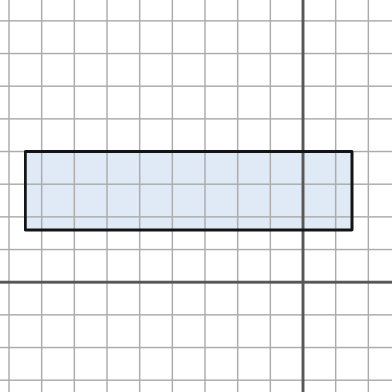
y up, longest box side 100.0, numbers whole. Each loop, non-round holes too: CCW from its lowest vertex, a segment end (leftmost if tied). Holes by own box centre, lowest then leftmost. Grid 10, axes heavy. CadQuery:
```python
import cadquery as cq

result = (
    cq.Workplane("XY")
    .moveTo(-85.0, 16.0)
    .lineTo(15.0, 16.0)
    .lineTo(15.0, 40.0)
    .lineTo(-85.0, 40.0)
    .close()
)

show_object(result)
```